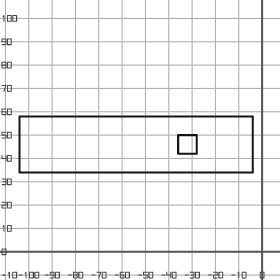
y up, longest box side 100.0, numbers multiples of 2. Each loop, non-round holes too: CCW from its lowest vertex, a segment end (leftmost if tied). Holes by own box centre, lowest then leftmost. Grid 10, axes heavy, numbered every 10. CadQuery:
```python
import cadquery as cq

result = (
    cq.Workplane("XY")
    .moveTo(-104.0, 34.0)
    .lineTo(-4.0, 34.0)
    .lineTo(-4.0, 58.0)
    .lineTo(-104.0, 58.0)
    .close()
    .moveTo(-36.0, 42.0)
    .lineTo(-28.0, 42.0)
    .lineTo(-28.0, 50.0)
    .lineTo(-36.0, 50.0)
    .close()
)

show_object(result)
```